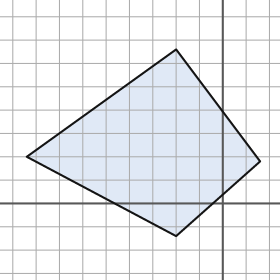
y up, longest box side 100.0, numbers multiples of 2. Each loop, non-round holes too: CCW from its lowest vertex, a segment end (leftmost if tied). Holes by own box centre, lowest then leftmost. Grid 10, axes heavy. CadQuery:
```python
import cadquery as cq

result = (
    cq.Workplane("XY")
    .moveTo(-20.0, -14.0)
    .lineTo(16.0, 18.0)
    .lineTo(-20.0, 66.0)
    .lineTo(-84.0, 20.0)
    .close()
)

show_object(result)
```